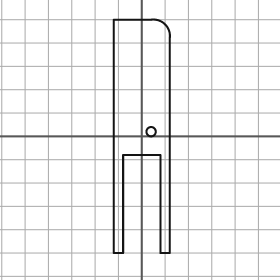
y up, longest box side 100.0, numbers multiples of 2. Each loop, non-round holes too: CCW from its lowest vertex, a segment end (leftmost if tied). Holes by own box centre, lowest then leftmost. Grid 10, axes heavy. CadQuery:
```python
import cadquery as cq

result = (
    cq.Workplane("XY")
    .moveTo(-12.0, -50.0)
    .lineTo(-8.0, -50.0)
    .lineTo(-8.0, -8.0)
    .lineTo(8.0, -8.0)
    .lineTo(8.0, -50.0)
    .lineTo(12.0, -50.0)
    .lineTo(12.0, 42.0)
    .threePointArc((10.0, 48.0), (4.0, 50.0))
    .lineTo(-12.0, 50.0)
    .close()
    .moveTo(4.0, 2.0)
    .circle(2.0)
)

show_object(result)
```